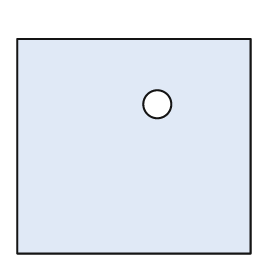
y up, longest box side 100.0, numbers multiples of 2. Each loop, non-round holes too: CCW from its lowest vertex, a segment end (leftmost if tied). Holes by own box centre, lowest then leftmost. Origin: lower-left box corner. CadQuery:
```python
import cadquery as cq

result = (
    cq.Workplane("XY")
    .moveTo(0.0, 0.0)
    .lineTo(100.0, 0.0)
    .lineTo(100.0, 92.0)
    .lineTo(0.0, 92.0)
    .close()
    .moveTo(60.0, 64.0)
    .circle(6.0)
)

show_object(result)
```